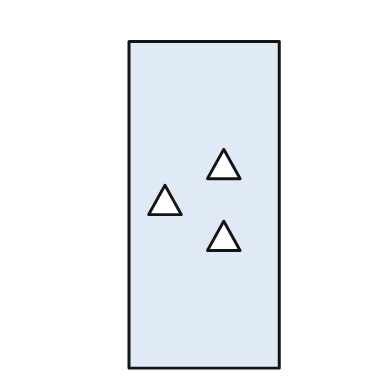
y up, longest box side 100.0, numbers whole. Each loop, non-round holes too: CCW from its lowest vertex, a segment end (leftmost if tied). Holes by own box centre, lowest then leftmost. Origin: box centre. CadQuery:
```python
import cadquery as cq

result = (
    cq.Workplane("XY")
    .moveTo(-23.0, -50.0)
    .lineTo(23.0, -50.0)
    .lineTo(23.0, 50.0)
    .lineTo(-23.0, 50.0)
    .close()
    .moveTo(1.0, -14.0)
    .lineTo(11.0, -14.0)
    .lineTo(6.0, -5.0)
    .close()
    .moveTo(-17.0, -3.0)
    .lineTo(-7.0, -3.0)
    .lineTo(-12.0, 6.0)
    .close()
    .moveTo(1.0, 8.0)
    .lineTo(11.0, 8.0)
    .lineTo(6.0, 17.0)
    .close()
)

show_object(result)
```